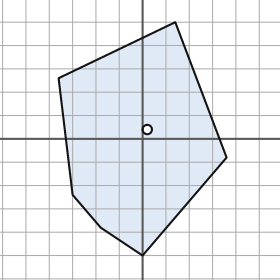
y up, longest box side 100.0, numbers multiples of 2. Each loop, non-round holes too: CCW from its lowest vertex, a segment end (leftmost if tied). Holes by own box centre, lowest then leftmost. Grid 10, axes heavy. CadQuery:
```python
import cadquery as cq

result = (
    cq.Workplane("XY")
    .moveTo(0.0, -50.0)
    .lineTo(36.0, -8.0)
    .lineTo(14.0, 50.0)
    .lineTo(-36.0, 26.0)
    .lineTo(-30.0, -24.0)
    .lineTo(-18.0, -38.0)
    .close()
    .moveTo(2.0, 4.0)
    .circle(2.0)
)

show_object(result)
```